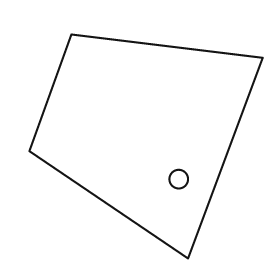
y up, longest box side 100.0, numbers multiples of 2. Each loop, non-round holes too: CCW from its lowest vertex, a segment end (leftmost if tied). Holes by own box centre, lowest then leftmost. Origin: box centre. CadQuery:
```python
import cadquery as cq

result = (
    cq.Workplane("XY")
    .moveTo(18.0, -48.0)
    .lineTo(50.0, 38.0)
    .lineTo(-32.0, 48.0)
    .lineTo(-50.0, -2.0)
    .close()
    .moveTo(14.0, -14.0)
    .circle(4.0)
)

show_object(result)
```